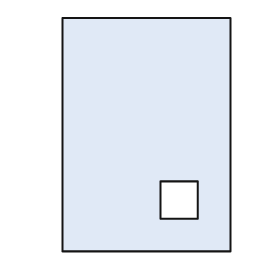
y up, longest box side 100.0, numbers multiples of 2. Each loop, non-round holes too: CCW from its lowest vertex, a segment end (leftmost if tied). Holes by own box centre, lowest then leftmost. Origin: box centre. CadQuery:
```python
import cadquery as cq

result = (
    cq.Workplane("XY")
    .moveTo(-36.0, -50.0)
    .lineTo(36.0, -50.0)
    .lineTo(36.0, 50.0)
    .lineTo(-36.0, 50.0)
    .close()
    .moveTo(6.0, -36.0)
    .lineTo(22.0, -36.0)
    .lineTo(22.0, -20.0)
    .lineTo(6.0, -20.0)
    .close()
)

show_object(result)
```